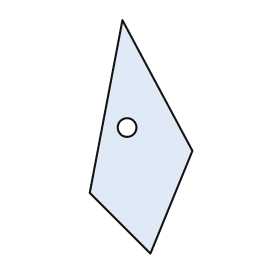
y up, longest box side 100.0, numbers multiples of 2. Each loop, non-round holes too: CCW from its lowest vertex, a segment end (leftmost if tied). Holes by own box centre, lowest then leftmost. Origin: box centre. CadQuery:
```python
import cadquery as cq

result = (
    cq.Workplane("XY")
    .moveTo(4.0, -50.0)
    .lineTo(22.0, -6.0)
    .lineTo(-8.0, 50.0)
    .lineTo(-22.0, -24.0)
    .close()
    .moveTo(-6.0, 4.0)
    .circle(4.0)
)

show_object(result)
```